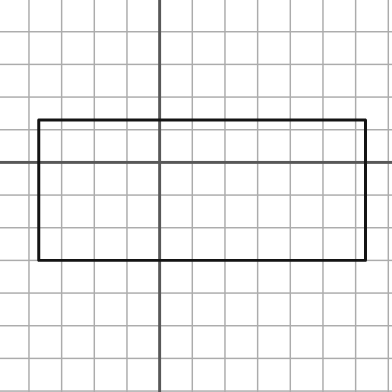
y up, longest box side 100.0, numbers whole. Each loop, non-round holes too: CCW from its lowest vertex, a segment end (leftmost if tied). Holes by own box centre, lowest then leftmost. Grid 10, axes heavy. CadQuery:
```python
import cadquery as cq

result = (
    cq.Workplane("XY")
    .moveTo(-37.0, -30.0)
    .lineTo(63.0, -30.0)
    .lineTo(63.0, 13.0)
    .lineTo(-37.0, 13.0)
    .close()
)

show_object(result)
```